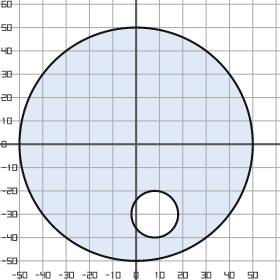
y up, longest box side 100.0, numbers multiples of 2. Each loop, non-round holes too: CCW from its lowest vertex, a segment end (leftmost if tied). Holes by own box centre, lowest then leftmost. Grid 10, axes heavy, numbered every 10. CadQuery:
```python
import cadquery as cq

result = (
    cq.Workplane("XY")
    .moveTo(0.0, 0.0)
    .circle(50.0)
    .moveTo(8.0, -30.0)
    .circle(10.0)
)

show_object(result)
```